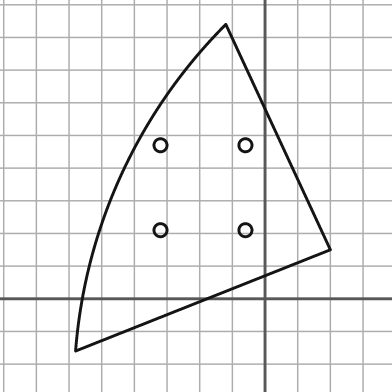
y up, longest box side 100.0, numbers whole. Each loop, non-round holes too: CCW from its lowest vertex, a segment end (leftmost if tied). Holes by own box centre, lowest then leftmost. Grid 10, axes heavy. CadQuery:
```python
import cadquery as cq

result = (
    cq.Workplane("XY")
    .moveTo(-58.0, -16.0)
    .lineTo(20.0, 15.0)
    .lineTo(-12.0, 84.0)
    .threePointArc((-44.0, 38.0), (-58.0, -16.0))
    .close()
    .moveTo(-32.0, 21.0)
    .circle(2.0)
    .moveTo(-6.0, 21.0)
    .circle(2.0)
    .moveTo(-32.0, 47.0)
    .circle(2.0)
    .moveTo(-6.0, 47.0)
    .circle(2.0)
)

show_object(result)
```